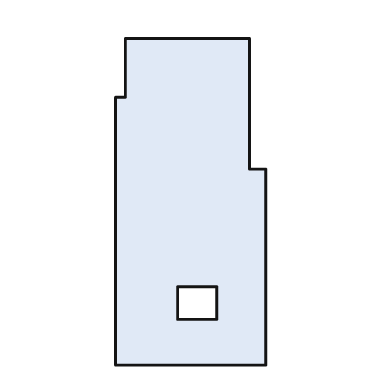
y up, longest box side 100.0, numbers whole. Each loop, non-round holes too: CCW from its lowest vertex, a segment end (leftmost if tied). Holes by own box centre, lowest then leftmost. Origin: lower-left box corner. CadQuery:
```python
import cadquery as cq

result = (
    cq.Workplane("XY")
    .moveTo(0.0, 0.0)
    .lineTo(46.0, 0.0)
    .lineTo(46.0, 60.0)
    .lineTo(41.0, 60.0)
    .lineTo(41.0, 100.0)
    .lineTo(3.0, 100.0)
    .lineTo(3.0, 82.0)
    .lineTo(0.0, 82.0)
    .close()
    .moveTo(19.0, 14.0)
    .lineTo(31.0, 14.0)
    .lineTo(31.0, 24.0)
    .lineTo(19.0, 24.0)
    .close()
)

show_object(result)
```